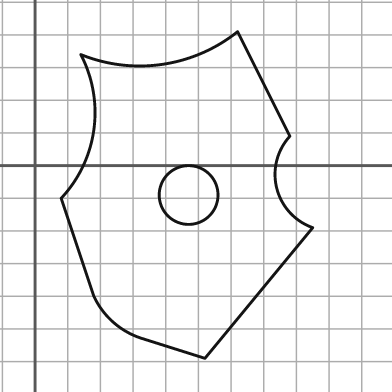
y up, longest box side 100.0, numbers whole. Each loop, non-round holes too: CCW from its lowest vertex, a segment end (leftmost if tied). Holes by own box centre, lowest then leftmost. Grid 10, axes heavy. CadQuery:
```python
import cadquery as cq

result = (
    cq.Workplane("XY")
    .moveTo(52.0, -59.0)
    .lineTo(85.0, -19.0)
    .threePointArc((74.0, -7.0), (78.0, 9.0))
    .lineTo(62.0, 41.0)
    .threePointArc((39.0, 31.0), (14.0, 34.0))
    .threePointArc((18.0, 11.0), (8.0, -10.0))
    .lineTo(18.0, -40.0)
    .threePointArc((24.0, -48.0), (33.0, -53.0))
    .close()
    .moveTo(47.0, -9.0)
    .circle(9.0)
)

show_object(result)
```